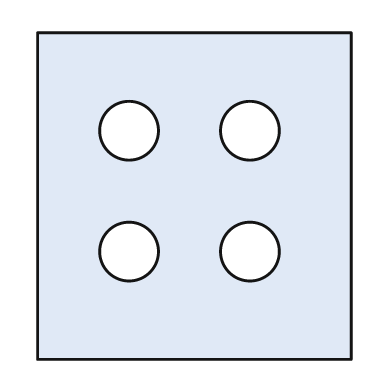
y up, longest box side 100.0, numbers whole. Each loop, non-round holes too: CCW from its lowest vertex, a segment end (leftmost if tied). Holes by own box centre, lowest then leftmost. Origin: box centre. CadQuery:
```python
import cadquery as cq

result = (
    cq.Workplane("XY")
    .moveTo(-48.0, -50.0)
    .lineTo(48.0, -50.0)
    .lineTo(48.0, 50.0)
    .lineTo(-48.0, 50.0)
    .close()
    .moveTo(-20.0, -17.0)
    .circle(9.0)
    .moveTo(17.0, -17.0)
    .circle(9.0)
    .moveTo(-20.0, 20.0)
    .circle(9.0)
    .moveTo(17.0, 20.0)
    .circle(9.0)
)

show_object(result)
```